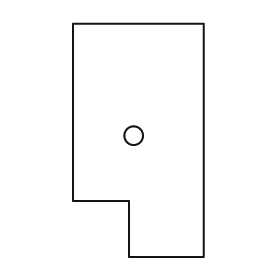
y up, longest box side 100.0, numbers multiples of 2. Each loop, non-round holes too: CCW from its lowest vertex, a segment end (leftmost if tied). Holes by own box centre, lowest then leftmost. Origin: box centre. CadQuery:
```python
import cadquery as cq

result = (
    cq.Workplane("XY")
    .moveTo(-4.0, -50.0)
    .lineTo(28.0, -50.0)
    .lineTo(28.0, 50.0)
    .lineTo(-28.0, 50.0)
    .lineTo(-28.0, -26.0)
    .lineTo(-4.0, -26.0)
    .close()
    .moveTo(-2.0, 2.0)
    .circle(4.0)
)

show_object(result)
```